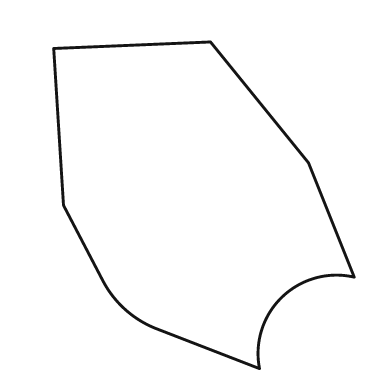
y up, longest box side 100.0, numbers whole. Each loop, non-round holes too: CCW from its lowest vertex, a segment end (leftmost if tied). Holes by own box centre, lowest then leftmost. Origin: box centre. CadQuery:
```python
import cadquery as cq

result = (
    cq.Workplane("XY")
    .moveTo(17.0, -50.0)
    .threePointArc((24.0, -28.0), (46.0, -22.0))
    .lineTo(32.0, 13.0)
    .lineTo(2.0, 50.0)
    .lineTo(-46.0, 48.0)
    .lineTo(-43.0, 0.0)
    .lineTo(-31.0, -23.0)
    .threePointArc((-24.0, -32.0), (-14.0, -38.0))
    .close()
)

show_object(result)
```